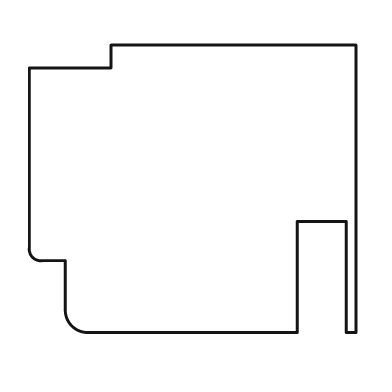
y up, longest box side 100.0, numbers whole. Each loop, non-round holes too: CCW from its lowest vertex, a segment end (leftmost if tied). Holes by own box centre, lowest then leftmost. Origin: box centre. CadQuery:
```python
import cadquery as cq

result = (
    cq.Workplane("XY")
    .moveTo(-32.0, -44.0)
    .lineTo(32.0, -44.0)
    .lineTo(32.0, -10.0)
    .lineTo(47.0, -10.0)
    .lineTo(47.0, -44.0)
    .lineTo(50.0, -44.0)
    .lineTo(50.0, 44.0)
    .lineTo(-25.0, 44.0)
    .lineTo(-25.0, 37.0)
    .lineTo(-50.0, 37.0)
    .lineTo(-50.0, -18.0)
    .threePointArc((-49.0, -21.0), (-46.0, -22.0))
    .lineTo(-39.0, -22.0)
    .lineTo(-39.0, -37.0)
    .threePointArc((-37.0, -42.0), (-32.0, -44.0))
    .close()
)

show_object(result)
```